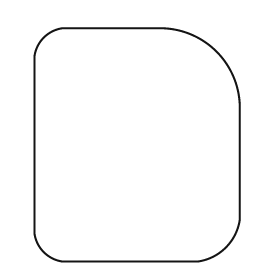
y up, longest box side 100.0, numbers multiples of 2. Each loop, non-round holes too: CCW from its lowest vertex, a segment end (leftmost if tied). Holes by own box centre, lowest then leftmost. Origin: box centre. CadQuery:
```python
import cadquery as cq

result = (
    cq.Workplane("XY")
    .moveTo(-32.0, -50.0)
    .lineTo(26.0, -50.0)
    .threePointArc((38.0, -44.0), (44.0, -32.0))
    .lineTo(44.0, 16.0)
    .threePointArc((34.0, 40.0), (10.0, 50.0))
    .lineTo(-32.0, 50.0)
    .threePointArc((-40.0, 46.0), (-44.0, 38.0))
    .lineTo(-44.0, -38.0)
    .threePointArc((-40.0, -46.0), (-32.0, -50.0))
    .close()
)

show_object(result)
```